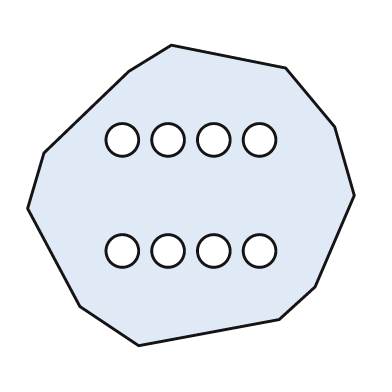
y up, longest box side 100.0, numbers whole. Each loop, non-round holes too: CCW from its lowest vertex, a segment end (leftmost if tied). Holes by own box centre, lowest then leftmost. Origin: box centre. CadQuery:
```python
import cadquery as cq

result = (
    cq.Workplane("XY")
    .moveTo(-16.0, -46.0)
    .lineTo(27.0, -38.0)
    .lineTo(38.0, -28.0)
    .lineTo(50.0, 0.0)
    .lineTo(44.0, 21.0)
    .lineTo(29.0, 39.0)
    .lineTo(-6.0, 46.0)
    .lineTo(-19.0, 38.0)
    .lineTo(-45.0, 13.0)
    .lineTo(-50.0, -4.0)
    .lineTo(-34.0, -34.0)
    .close()
    .moveTo(-21.0, -17.0)
    .circle(5.0)
    .moveTo(-7.0, -17.0)
    .circle(5.0)
    .moveTo(7.0, -17.0)
    .circle(5.0)
    .moveTo(21.0, -17.0)
    .circle(5.0)
    .moveTo(-21.0, 17.0)
    .circle(5.0)
    .moveTo(-7.0, 17.0)
    .circle(5.0)
    .moveTo(7.0, 17.0)
    .circle(5.0)
    .moveTo(21.0, 17.0)
    .circle(5.0)
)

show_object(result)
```